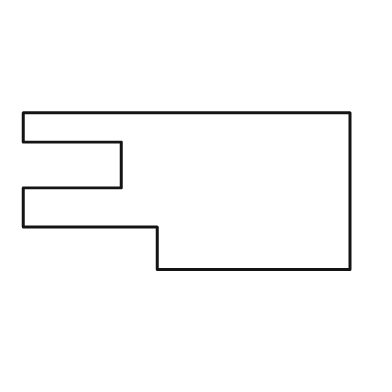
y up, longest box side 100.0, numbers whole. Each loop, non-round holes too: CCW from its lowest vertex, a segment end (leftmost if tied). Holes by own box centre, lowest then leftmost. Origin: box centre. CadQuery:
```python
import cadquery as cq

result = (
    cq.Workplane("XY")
    .moveTo(-9.0, -24.0)
    .lineTo(50.0, -24.0)
    .lineTo(50.0, 24.0)
    .lineTo(-50.0, 24.0)
    .lineTo(-50.0, 15.0)
    .lineTo(-20.0, 15.0)
    .lineTo(-20.0, 1.0)
    .lineTo(-50.0, 1.0)
    .lineTo(-50.0, -11.0)
    .lineTo(-9.0, -11.0)
    .close()
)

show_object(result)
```